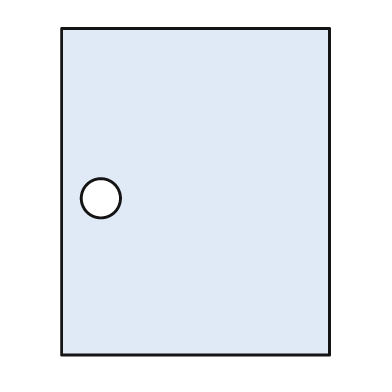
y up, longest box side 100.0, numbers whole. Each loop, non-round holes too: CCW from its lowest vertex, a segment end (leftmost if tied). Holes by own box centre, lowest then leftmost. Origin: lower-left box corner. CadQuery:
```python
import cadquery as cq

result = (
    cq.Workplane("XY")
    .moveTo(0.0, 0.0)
    .lineTo(82.0, 0.0)
    .lineTo(82.0, 100.0)
    .lineTo(0.0, 100.0)
    .close()
    .moveTo(12.0, 48.0)
    .circle(6.0)
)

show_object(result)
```